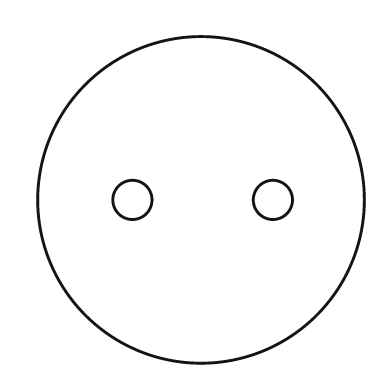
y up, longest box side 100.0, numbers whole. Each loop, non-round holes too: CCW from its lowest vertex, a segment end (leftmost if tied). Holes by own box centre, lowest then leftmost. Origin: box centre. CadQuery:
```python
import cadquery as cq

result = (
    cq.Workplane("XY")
    .moveTo(0.0, 0.0)
    .circle(50.0)
    .moveTo(-21.0, 0.0)
    .circle(6.0)
    .moveTo(22.0, 0.0)
    .circle(6.0)
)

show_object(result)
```